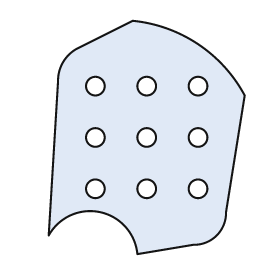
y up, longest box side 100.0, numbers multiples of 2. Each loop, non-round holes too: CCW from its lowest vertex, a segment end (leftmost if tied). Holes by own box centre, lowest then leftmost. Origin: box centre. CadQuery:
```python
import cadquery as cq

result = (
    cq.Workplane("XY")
    .moveTo(-4.0, -50.0)
    .lineTo(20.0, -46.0)
    .threePointArc((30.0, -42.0), (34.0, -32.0))
    .lineTo(42.0, 18.0)
    .threePointArc((22.0, 40.0), (-6.0, 50.0))
    .lineTo(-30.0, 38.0)
    .threePointArc((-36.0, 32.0), (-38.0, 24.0))
    .lineTo(-42.0, -42.0)
    .threePointArc((-20.0, -32.0), (-4.0, -50.0))
    .close()
    .moveTo(-22.0, -22.0)
    .circle(4.0)
    .moveTo(0.0, -22.0)
    .circle(4.0)
    .moveTo(22.0, -22.0)
    .circle(4.0)
    .moveTo(-22.0, 0.0)
    .circle(4.0)
    .moveTo(0.0, 0.0)
    .circle(4.0)
    .moveTo(22.0, 0.0)
    .circle(4.0)
    .moveTo(-22.0, 22.0)
    .circle(4.0)
    .moveTo(0.0, 22.0)
    .circle(4.0)
    .moveTo(22.0, 22.0)
    .circle(4.0)
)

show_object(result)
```